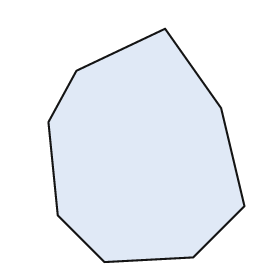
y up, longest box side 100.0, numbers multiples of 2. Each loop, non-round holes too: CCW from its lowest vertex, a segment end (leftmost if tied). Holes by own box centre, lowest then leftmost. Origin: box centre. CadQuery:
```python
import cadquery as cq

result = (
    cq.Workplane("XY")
    .moveTo(-18.0, -50.0)
    .lineTo(20.0, -48.0)
    .lineTo(42.0, -26.0)
    .lineTo(32.0, 16.0)
    .lineTo(8.0, 50.0)
    .lineTo(-30.0, 32.0)
    .lineTo(-42.0, 10.0)
    .lineTo(-38.0, -30.0)
    .close()
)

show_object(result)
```